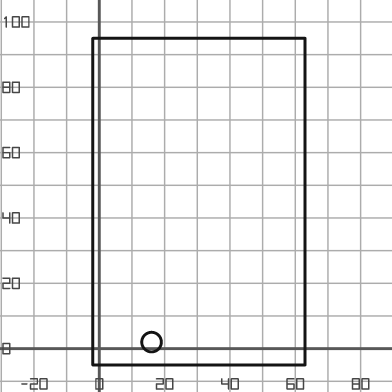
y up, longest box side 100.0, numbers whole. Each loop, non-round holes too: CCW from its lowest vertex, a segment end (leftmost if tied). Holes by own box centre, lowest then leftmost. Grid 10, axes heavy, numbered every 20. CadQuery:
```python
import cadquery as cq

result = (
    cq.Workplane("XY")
    .moveTo(-2.0, -5.0)
    .lineTo(63.0, -5.0)
    .lineTo(63.0, 95.0)
    .lineTo(-2.0, 95.0)
    .close()
    .moveTo(16.0, 2.0)
    .circle(3.0)
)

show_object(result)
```